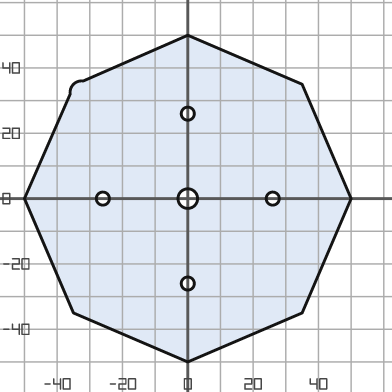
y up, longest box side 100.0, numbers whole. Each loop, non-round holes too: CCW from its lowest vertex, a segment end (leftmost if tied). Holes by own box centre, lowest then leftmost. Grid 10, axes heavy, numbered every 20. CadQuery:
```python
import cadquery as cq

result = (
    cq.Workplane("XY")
    .moveTo(0.0, -50.0)
    .lineTo(35.0, -35.0)
    .lineTo(50.0, 0.0)
    .lineTo(35.0, 35.0)
    .lineTo(0.0, 50.0)
    .lineTo(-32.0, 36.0)
    .threePointArc((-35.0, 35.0), (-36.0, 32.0))
    .lineTo(-50.0, 0.0)
    .lineTo(-35.0, -35.0)
    .close()
    .moveTo(0.0, -26.0)
    .circle(2.0)
    .moveTo(-26.0, 0.0)
    .circle(2.0)
    .moveTo(0.0, 0.0)
    .circle(3.0)
    .moveTo(26.0, 0.0)
    .circle(2.0)
    .moveTo(0.0, 26.0)
    .circle(2.0)
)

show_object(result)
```